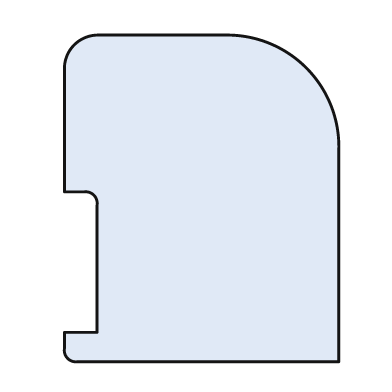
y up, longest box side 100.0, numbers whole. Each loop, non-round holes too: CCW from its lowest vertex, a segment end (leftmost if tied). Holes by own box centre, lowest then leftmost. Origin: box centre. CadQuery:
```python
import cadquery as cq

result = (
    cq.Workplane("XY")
    .moveTo(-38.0, -50.0)
    .lineTo(42.0, -50.0)
    .lineTo(42.0, 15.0)
    .threePointArc((32.0, 40.0), (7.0, 50.0))
    .lineTo(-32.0, 50.0)
    .threePointArc((-39.0, 47.0), (-42.0, 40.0))
    .lineTo(-42.0, 2.0)
    .lineTo(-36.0, 2.0)
    .threePointArc((-33.0, 1.0), (-32.0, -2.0))
    .lineTo(-32.0, -41.0)
    .lineTo(-42.0, -41.0)
    .lineTo(-42.0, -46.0)
    .threePointArc((-41.0, -49.0), (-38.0, -50.0))
    .close()
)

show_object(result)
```